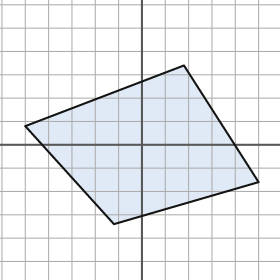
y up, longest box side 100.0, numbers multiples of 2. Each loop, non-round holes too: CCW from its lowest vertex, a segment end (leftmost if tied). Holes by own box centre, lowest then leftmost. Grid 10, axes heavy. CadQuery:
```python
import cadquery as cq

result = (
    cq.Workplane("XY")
    .moveTo(-12.0, -34.0)
    .lineTo(50.0, -16.0)
    .lineTo(18.0, 34.0)
    .lineTo(-50.0, 8.0)
    .close()
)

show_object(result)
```